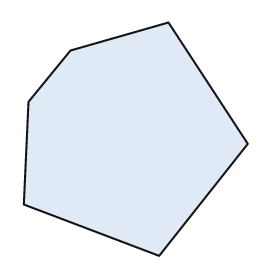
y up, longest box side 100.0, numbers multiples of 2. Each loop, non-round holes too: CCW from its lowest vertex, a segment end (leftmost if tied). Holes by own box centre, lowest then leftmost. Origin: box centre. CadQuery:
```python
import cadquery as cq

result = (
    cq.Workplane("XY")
    .moveTo(10.0, -50.0)
    .lineTo(48.0, -2.0)
    .lineTo(14.0, 50.0)
    .lineTo(-28.0, 38.0)
    .lineTo(-46.0, 16.0)
    .lineTo(-48.0, -28.0)
    .close()
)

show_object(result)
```